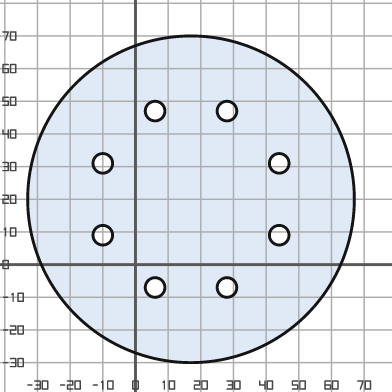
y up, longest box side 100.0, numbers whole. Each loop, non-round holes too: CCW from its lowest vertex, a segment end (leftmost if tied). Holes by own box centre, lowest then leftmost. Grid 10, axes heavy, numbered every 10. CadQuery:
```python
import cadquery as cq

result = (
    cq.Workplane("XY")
    .moveTo(17.0, 20.0)
    .circle(50.0)
    .moveTo(6.0, -7.0)
    .circle(3.0)
    .moveTo(28.0, -7.0)
    .circle(3.0)
    .moveTo(-10.0, 9.0)
    .circle(3.0)
    .moveTo(44.0, 9.0)
    .circle(3.0)
    .moveTo(-10.0, 31.0)
    .circle(3.0)
    .moveTo(44.0, 31.0)
    .circle(3.0)
    .moveTo(6.0, 47.0)
    .circle(3.0)
    .moveTo(28.0, 47.0)
    .circle(3.0)
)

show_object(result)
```